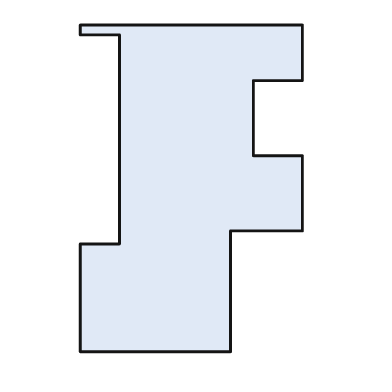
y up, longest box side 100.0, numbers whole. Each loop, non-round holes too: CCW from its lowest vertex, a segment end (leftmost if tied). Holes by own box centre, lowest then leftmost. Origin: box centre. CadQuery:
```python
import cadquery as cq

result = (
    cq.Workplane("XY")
    .moveTo(-34.0, -50.0)
    .lineTo(12.0, -50.0)
    .lineTo(12.0, -13.0)
    .lineTo(34.0, -13.0)
    .lineTo(34.0, 10.0)
    .lineTo(19.0, 10.0)
    .lineTo(19.0, 33.0)
    .lineTo(34.0, 33.0)
    .lineTo(34.0, 50.0)
    .lineTo(-34.0, 50.0)
    .lineTo(-34.0, 47.0)
    .lineTo(-22.0, 47.0)
    .lineTo(-22.0, -17.0)
    .lineTo(-34.0, -17.0)
    .close()
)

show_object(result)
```